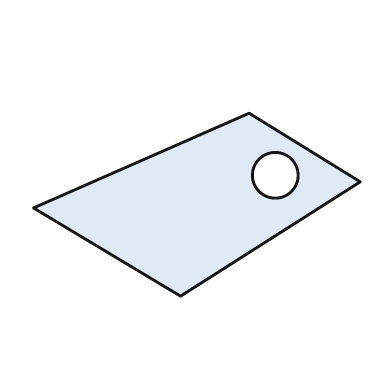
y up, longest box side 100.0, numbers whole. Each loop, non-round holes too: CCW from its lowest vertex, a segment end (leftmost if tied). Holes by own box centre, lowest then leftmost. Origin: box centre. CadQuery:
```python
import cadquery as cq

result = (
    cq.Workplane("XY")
    .moveTo(-5.0, -28.0)
    .lineTo(50.0, 7.0)
    .lineTo(16.0, 28.0)
    .lineTo(-50.0, -1.0)
    .close()
    .moveTo(24.0, 9.0)
    .circle(7.0)
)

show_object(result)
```